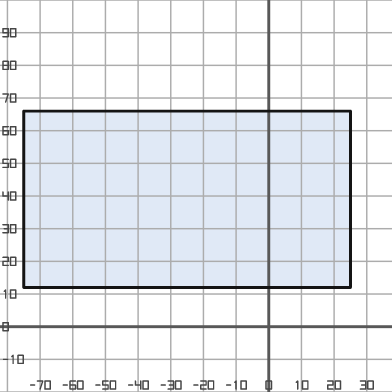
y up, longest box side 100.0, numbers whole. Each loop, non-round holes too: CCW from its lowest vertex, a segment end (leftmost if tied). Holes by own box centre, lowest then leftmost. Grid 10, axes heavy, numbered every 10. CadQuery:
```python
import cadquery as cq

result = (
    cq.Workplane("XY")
    .moveTo(-75.0, 12.0)
    .lineTo(25.0, 12.0)
    .lineTo(25.0, 66.0)
    .lineTo(-75.0, 66.0)
    .close()
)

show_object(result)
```